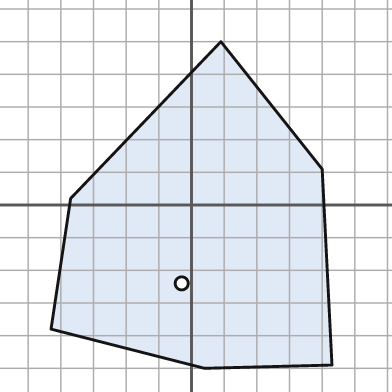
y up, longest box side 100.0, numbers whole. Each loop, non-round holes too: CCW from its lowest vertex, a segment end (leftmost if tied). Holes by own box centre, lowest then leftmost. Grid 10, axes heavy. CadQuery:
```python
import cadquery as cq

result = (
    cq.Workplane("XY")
    .moveTo(4.0, -50.0)
    .lineTo(43.0, -49.0)
    .lineTo(40.0, 11.0)
    .lineTo(9.0, 50.0)
    .lineTo(-37.0, 2.0)
    .lineTo(-43.0, -38.0)
    .close()
    .moveTo(-3.0, -24.0)
    .circle(2.0)
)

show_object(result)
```